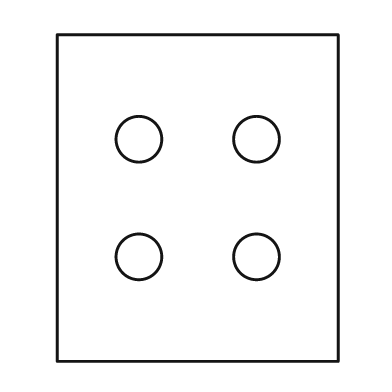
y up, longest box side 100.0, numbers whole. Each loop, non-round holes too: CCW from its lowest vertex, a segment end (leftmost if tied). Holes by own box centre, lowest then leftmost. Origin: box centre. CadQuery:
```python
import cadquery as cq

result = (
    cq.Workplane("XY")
    .moveTo(-43.0, -50.0)
    .lineTo(43.0, -50.0)
    .lineTo(43.0, 50.0)
    .lineTo(-43.0, 50.0)
    .close()
    .moveTo(-18.0, -18.0)
    .circle(7.0)
    .moveTo(18.0, -18.0)
    .circle(7.0)
    .moveTo(-18.0, 18.0)
    .circle(7.0)
    .moveTo(18.0, 18.0)
    .circle(7.0)
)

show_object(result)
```